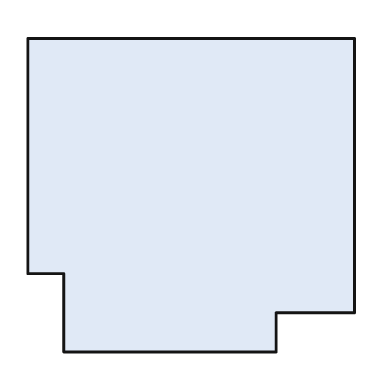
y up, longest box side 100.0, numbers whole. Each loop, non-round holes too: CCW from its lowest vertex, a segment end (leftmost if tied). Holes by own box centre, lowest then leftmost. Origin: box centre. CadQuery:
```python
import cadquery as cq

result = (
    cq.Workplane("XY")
    .moveTo(-39.0, -48.0)
    .lineTo(26.0, -48.0)
    .lineTo(26.0, -36.0)
    .lineTo(50.0, -36.0)
    .lineTo(50.0, 48.0)
    .lineTo(-50.0, 48.0)
    .lineTo(-50.0, -24.0)
    .lineTo(-39.0, -24.0)
    .close()
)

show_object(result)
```